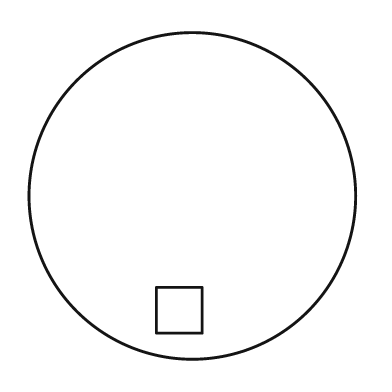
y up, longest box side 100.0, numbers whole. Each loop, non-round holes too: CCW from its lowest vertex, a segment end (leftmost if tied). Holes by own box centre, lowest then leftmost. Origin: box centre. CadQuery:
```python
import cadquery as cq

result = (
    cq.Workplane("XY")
    .moveTo(0.0, 0.0)
    .circle(50.0)
    .moveTo(-11.0, -42.0)
    .lineTo(3.0, -42.0)
    .lineTo(3.0, -28.0)
    .lineTo(-11.0, -28.0)
    .close()
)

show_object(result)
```